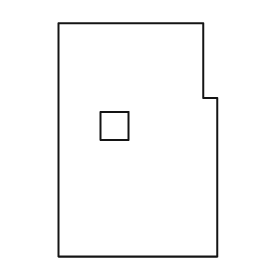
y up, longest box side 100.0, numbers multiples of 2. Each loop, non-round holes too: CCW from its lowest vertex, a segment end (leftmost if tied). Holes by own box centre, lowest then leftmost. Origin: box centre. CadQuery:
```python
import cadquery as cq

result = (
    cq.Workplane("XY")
    .moveTo(-34.0, -50.0)
    .lineTo(34.0, -50.0)
    .lineTo(34.0, 18.0)
    .lineTo(28.0, 18.0)
    .lineTo(28.0, 50.0)
    .lineTo(-34.0, 50.0)
    .close()
    .moveTo(-16.0, 0.0)
    .lineTo(-4.0, 0.0)
    .lineTo(-4.0, 12.0)
    .lineTo(-16.0, 12.0)
    .close()
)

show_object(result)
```